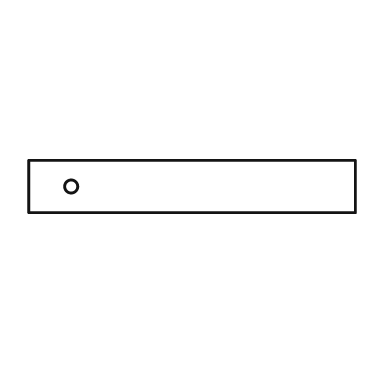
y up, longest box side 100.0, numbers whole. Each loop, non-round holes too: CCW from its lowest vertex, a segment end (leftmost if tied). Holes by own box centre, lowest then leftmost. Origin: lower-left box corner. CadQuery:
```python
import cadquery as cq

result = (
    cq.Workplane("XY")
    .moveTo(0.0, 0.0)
    .lineTo(100.0, 0.0)
    .lineTo(100.0, 16.0)
    .lineTo(0.0, 16.0)
    .close()
    .moveTo(13.0, 8.0)
    .circle(2.0)
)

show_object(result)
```